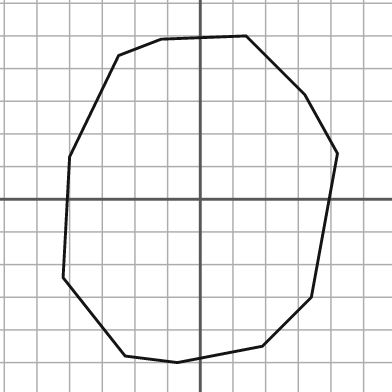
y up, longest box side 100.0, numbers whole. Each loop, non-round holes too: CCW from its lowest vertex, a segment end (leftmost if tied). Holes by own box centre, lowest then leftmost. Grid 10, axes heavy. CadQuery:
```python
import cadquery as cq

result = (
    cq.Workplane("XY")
    .moveTo(-7.0, -50.0)
    .lineTo(19.0, -45.0)
    .lineTo(34.0, -30.0)
    .lineTo(42.0, 14.0)
    .lineTo(32.0, 32.0)
    .lineTo(14.0, 50.0)
    .lineTo(-12.0, 49.0)
    .lineTo(-25.0, 44.0)
    .lineTo(-40.0, 13.0)
    .lineTo(-42.0, -24.0)
    .lineTo(-23.0, -48.0)
    .close()
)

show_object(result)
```